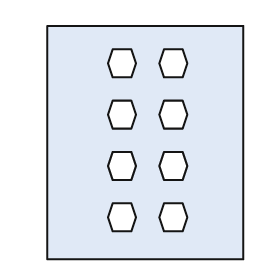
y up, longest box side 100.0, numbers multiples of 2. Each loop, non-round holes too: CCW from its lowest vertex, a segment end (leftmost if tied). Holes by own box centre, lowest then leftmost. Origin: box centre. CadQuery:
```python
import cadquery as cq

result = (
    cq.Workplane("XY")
    .moveTo(-42.0, -50.0)
    .lineTo(42.0, -50.0)
    .lineTo(42.0, 50.0)
    .lineTo(-42.0, 50.0)
    .close()
    .moveTo(-14.0, -38.0)
    .lineTo(-6.0, -38.0)
    .lineTo(-4.0, -32.0)
    .lineTo(-6.0, -26.0)
    .lineTo(-14.0, -26.0)
    .lineTo(-16.0, -32.0)
    .close()
    .moveTo(8.0, -38.0)
    .lineTo(16.0, -38.0)
    .lineTo(18.0, -32.0)
    .lineTo(16.0, -26.0)
    .lineTo(8.0, -26.0)
    .lineTo(6.0, -32.0)
    .close()
    .moveTo(-14.0, -16.0)
    .lineTo(-6.0, -16.0)
    .lineTo(-4.0, -10.0)
    .lineTo(-6.0, -4.0)
    .lineTo(-14.0, -4.0)
    .lineTo(-16.0, -10.0)
    .close()
    .moveTo(8.0, -16.0)
    .lineTo(16.0, -16.0)
    .lineTo(18.0, -10.0)
    .lineTo(16.0, -4.0)
    .lineTo(8.0, -4.0)
    .lineTo(6.0, -10.0)
    .close()
    .moveTo(-14.0, 6.0)
    .lineTo(-6.0, 6.0)
    .lineTo(-4.0, 12.0)
    .lineTo(-6.0, 18.0)
    .lineTo(-14.0, 18.0)
    .lineTo(-16.0, 12.0)
    .close()
    .moveTo(8.0, 6.0)
    .lineTo(16.0, 6.0)
    .lineTo(18.0, 12.0)
    .lineTo(16.0, 18.0)
    .lineTo(8.0, 18.0)
    .lineTo(6.0, 12.0)
    .close()
    .moveTo(-14.0, 28.0)
    .lineTo(-6.0, 28.0)
    .lineTo(-4.0, 34.0)
    .lineTo(-6.0, 40.0)
    .lineTo(-14.0, 40.0)
    .lineTo(-16.0, 34.0)
    .close()
    .moveTo(8.0, 28.0)
    .lineTo(16.0, 28.0)
    .lineTo(18.0, 34.0)
    .lineTo(16.0, 40.0)
    .lineTo(8.0, 40.0)
    .lineTo(6.0, 34.0)
    .close()
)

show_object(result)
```